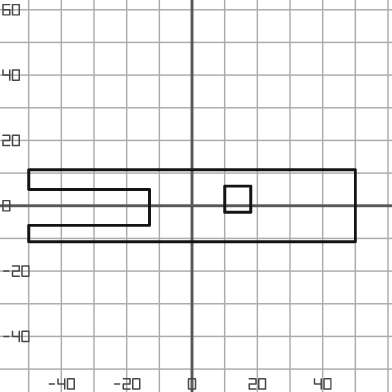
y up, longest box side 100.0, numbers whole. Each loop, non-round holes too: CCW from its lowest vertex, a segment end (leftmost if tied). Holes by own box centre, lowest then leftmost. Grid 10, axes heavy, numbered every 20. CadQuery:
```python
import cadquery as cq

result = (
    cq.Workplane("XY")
    .moveTo(-50.0, -11.0)
    .lineTo(50.0, -11.0)
    .lineTo(50.0, 11.0)
    .lineTo(-50.0, 11.0)
    .lineTo(-50.0, 5.0)
    .lineTo(-13.0, 5.0)
    .lineTo(-13.0, -6.0)
    .lineTo(-50.0, -6.0)
    .close()
    .moveTo(10.0, -2.0)
    .lineTo(18.0, -2.0)
    .lineTo(18.0, 6.0)
    .lineTo(10.0, 6.0)
    .close()
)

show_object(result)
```